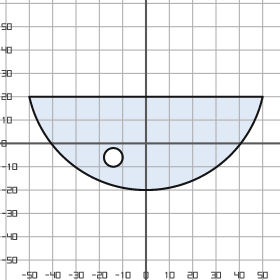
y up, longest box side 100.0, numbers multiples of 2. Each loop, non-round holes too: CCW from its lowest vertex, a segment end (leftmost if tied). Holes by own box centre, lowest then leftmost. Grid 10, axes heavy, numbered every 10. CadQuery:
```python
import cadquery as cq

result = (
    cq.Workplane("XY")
    .moveTo(-50.0, 20.0)
    .threePointArc((0.0, -20.0), (50.0, 20.0))
    .close()
    .moveTo(-14.0, -6.0)
    .circle(4.0)
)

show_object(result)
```